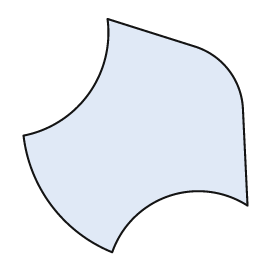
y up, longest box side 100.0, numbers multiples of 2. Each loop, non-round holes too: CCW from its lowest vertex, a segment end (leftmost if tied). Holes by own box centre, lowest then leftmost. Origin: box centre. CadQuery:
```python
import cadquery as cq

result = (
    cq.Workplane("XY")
    .moveTo(-10.0, -50.0)
    .threePointArc((14.0, -26.0), (48.0, -30.0))
    .lineTo(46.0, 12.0)
    .threePointArc((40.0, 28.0), (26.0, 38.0))
    .lineTo(-12.0, 50.0)
    .threePointArc((-20.0, 18.0), (-48.0, 0.0))
    .threePointArc((-36.0, -30.0), (-10.0, -50.0))
    .close()
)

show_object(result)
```